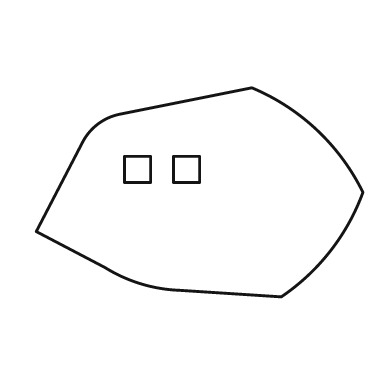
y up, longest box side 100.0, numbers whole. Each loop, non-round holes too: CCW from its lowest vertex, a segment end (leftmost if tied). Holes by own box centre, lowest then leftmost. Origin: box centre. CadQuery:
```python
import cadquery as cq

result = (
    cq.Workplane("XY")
    .moveTo(25.0, -32.0)
    .threePointArc((40.0, -18.0), (50.0, 0.0))
    .threePointArc((36.0, 19.0), (16.0, 32.0))
    .lineTo(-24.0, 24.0)
    .threePointArc((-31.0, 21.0), (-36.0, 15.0))
    .lineTo(-50.0, -12.0)
    .lineTo(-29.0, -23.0)
    .threePointArc((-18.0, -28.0), (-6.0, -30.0))
    .close()
    .moveTo(-23.0, 3.0)
    .lineTo(-15.0, 3.0)
    .lineTo(-15.0, 11.0)
    .lineTo(-23.0, 11.0)
    .close()
    .moveTo(-8.0, 3.0)
    .lineTo(0.0, 3.0)
    .lineTo(0.0, 11.0)
    .lineTo(-8.0, 11.0)
    .close()
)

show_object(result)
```